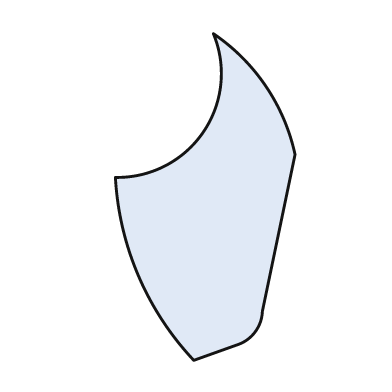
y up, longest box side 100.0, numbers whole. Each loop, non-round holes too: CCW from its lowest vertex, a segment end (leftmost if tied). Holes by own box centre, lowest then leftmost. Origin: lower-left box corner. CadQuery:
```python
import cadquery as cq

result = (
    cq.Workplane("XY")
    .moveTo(24.0, 0.0)
    .lineTo(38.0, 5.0)
    .threePointArc((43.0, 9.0), (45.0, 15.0))
    .lineTo(55.0, 63.0)
    .threePointArc((46.0, 84.0), (30.0, 100.0))
    .threePointArc((27.0, 70.0), (0.0, 56.0))
    .threePointArc((7.0, 26.0), (24.0, 0.0))
    .close()
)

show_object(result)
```